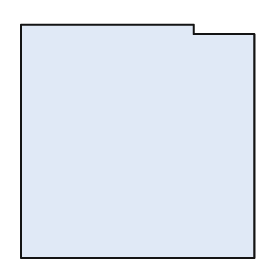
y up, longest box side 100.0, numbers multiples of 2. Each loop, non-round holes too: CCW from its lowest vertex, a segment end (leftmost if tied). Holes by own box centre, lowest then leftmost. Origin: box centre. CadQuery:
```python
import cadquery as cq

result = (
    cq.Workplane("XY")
    .moveTo(-50.0, -50.0)
    .lineTo(50.0, -50.0)
    .lineTo(50.0, 46.0)
    .lineTo(24.0, 46.0)
    .lineTo(24.0, 50.0)
    .lineTo(-50.0, 50.0)
    .close()
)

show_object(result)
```